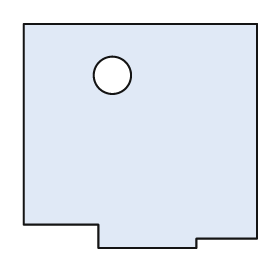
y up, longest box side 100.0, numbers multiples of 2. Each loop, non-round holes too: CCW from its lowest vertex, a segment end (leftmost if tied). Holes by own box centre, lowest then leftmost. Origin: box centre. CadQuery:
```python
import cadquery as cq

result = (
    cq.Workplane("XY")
    .moveTo(-18.0, -48.0)
    .lineTo(24.0, -48.0)
    .lineTo(24.0, -44.0)
    .lineTo(50.0, -44.0)
    .lineTo(50.0, 48.0)
    .lineTo(-50.0, 48.0)
    .lineTo(-50.0, -38.0)
    .lineTo(-18.0, -38.0)
    .close()
    .moveTo(-12.0, 26.0)
    .circle(8.0)
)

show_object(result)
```